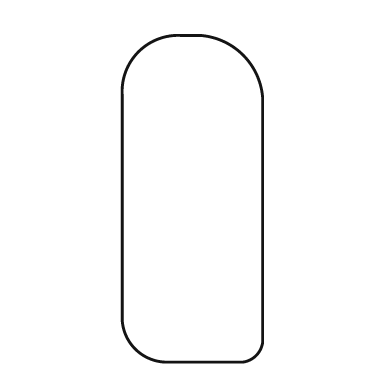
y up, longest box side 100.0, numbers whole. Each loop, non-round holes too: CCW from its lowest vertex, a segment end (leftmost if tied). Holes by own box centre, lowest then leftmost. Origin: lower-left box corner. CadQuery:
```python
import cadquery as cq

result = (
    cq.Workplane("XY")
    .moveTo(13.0, 0.0)
    .lineTo(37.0, 0.0)
    .threePointArc((41.0, 2.0), (43.0, 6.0))
    .lineTo(43.0, 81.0)
    .threePointArc((37.0, 94.0), (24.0, 100.0))
    .lineTo(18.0, 100.0)
    .threePointArc((5.0, 95.0), (0.0, 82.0))
    .lineTo(0.0, 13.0)
    .threePointArc((4.0, 4.0), (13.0, 0.0))
    .close()
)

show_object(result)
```